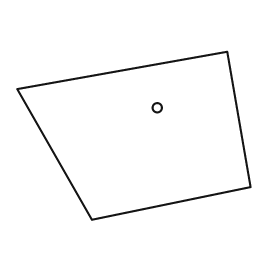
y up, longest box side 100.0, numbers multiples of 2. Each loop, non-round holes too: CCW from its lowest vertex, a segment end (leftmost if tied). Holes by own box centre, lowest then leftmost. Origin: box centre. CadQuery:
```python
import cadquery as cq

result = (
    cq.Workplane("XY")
    .moveTo(-18.0, -36.0)
    .lineTo(50.0, -22.0)
    .lineTo(40.0, 36.0)
    .lineTo(-50.0, 20.0)
    .close()
    .moveTo(10.0, 12.0)
    .circle(2.0)
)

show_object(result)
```